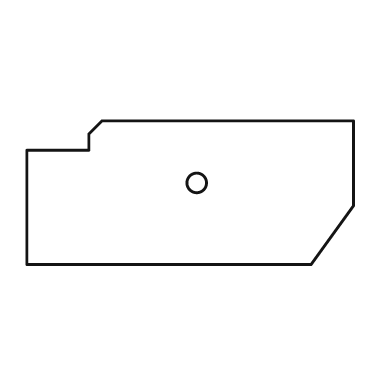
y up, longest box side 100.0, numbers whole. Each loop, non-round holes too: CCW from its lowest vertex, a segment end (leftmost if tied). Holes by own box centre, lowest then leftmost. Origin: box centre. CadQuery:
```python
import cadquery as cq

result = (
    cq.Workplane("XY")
    .moveTo(-50.0, -22.0)
    .lineTo(37.0, -22.0)
    .lineTo(50.0, -4.0)
    .lineTo(50.0, 22.0)
    .lineTo(-27.0, 22.0)
    .lineTo(-31.0, 18.0)
    .lineTo(-31.0, 13.0)
    .lineTo(-50.0, 13.0)
    .close()
    .moveTo(2.0, 3.0)
    .circle(3.0)
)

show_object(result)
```